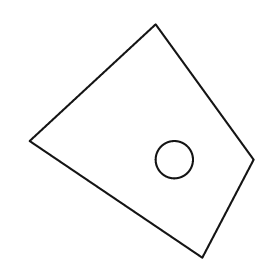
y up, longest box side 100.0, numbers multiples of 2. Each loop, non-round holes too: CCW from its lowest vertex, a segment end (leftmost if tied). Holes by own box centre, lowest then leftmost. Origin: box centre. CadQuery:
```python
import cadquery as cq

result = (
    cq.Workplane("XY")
    .moveTo(26.0, -50.0)
    .lineTo(48.0, -8.0)
    .lineTo(6.0, 50.0)
    .lineTo(-48.0, 0.0)
    .close()
    .moveTo(14.0, -8.0)
    .circle(8.0)
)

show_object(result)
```